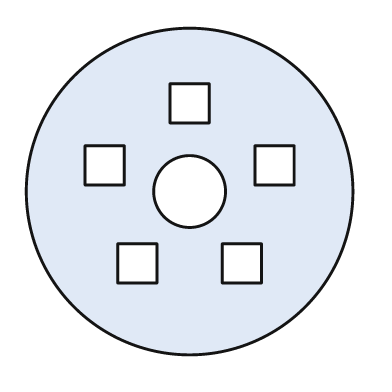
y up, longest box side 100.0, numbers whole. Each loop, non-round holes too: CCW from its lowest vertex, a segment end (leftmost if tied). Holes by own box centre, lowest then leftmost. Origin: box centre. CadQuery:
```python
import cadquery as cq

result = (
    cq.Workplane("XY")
    .moveTo(0.0, 0.0)
    .circle(50.0)
    .moveTo(-22.0, -28.0)
    .lineTo(-10.0, -28.0)
    .lineTo(-10.0, -16.0)
    .lineTo(-22.0, -16.0)
    .close()
    .moveTo(10.0, -28.0)
    .lineTo(22.0, -28.0)
    .lineTo(22.0, -16.0)
    .lineTo(10.0, -16.0)
    .close()
    .moveTo(0.0, 0.0)
    .circle(11.0)
    .moveTo(-32.0, 2.0)
    .lineTo(-20.0, 2.0)
    .lineTo(-20.0, 14.0)
    .lineTo(-32.0, 14.0)
    .close()
    .moveTo(20.0, 2.0)
    .lineTo(32.0, 2.0)
    .lineTo(32.0, 14.0)
    .lineTo(20.0, 14.0)
    .close()
    .moveTo(-6.0, 21.0)
    .lineTo(6.0, 21.0)
    .lineTo(6.0, 33.0)
    .lineTo(-6.0, 33.0)
    .close()
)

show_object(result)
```